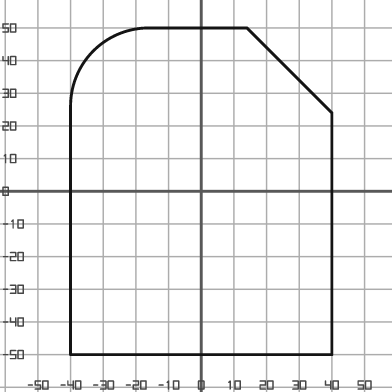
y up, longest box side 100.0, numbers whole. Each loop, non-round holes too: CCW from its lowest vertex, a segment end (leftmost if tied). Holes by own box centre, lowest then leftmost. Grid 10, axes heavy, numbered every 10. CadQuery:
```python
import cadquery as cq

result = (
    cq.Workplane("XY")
    .moveTo(-40.0, -50.0)
    .lineTo(40.0, -50.0)
    .lineTo(40.0, 24.0)
    .lineTo(14.0, 50.0)
    .lineTo(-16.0, 50.0)
    .threePointArc((-33.0, 43.0), (-40.0, 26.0))
    .close()
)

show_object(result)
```